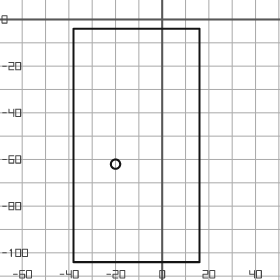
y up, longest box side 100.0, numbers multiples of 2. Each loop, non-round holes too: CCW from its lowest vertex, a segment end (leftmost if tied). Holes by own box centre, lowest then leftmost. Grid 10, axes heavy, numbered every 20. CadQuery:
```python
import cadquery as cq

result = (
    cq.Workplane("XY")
    .moveTo(-38.0, -104.0)
    .lineTo(16.0, -104.0)
    .lineTo(16.0, -4.0)
    .lineTo(-38.0, -4.0)
    .close()
    .moveTo(-20.0, -62.0)
    .circle(2.0)
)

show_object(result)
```